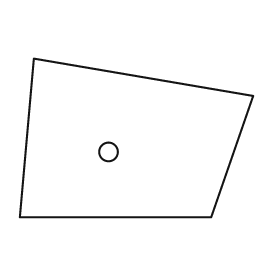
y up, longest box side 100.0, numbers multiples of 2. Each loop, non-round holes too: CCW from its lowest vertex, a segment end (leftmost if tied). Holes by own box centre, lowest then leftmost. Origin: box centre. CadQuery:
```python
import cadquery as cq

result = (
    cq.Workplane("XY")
    .moveTo(-50.0, -34.0)
    .lineTo(32.0, -34.0)
    .lineTo(50.0, 18.0)
    .lineTo(-44.0, 34.0)
    .close()
    .moveTo(-12.0, -6.0)
    .circle(4.0)
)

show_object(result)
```